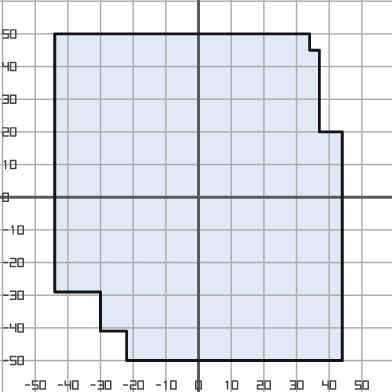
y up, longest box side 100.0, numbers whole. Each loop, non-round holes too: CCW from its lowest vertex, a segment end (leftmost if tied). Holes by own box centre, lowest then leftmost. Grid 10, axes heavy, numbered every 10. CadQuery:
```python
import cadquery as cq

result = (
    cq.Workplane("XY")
    .moveTo(-22.0, -50.0)
    .lineTo(44.0, -50.0)
    .lineTo(44.0, 20.0)
    .lineTo(37.0, 20.0)
    .lineTo(37.0, 45.0)
    .lineTo(34.0, 45.0)
    .lineTo(34.0, 50.0)
    .lineTo(-44.0, 50.0)
    .lineTo(-44.0, -29.0)
    .lineTo(-30.0, -29.0)
    .lineTo(-30.0, -41.0)
    .lineTo(-22.0, -41.0)
    .close()
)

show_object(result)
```